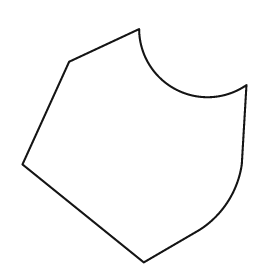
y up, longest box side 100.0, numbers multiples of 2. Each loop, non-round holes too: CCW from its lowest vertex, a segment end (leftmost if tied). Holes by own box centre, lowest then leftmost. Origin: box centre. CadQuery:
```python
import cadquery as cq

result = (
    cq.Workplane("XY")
    .moveTo(4.0, -50.0)
    .lineTo(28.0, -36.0)
    .threePointArc((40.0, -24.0), (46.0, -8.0))
    .lineTo(48.0, 26.0)
    .threePointArc((18.0, 24.0), (2.0, 50.0))
    .lineTo(-28.0, 36.0)
    .lineTo(-48.0, -8.0)
    .close()
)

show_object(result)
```